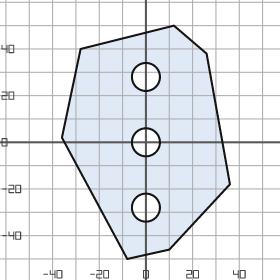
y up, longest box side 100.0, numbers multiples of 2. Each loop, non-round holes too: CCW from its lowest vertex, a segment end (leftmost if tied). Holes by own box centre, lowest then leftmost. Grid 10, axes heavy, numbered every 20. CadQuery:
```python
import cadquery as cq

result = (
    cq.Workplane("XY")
    .moveTo(-8.0, -50.0)
    .lineTo(10.0, -46.0)
    .lineTo(36.0, -18.0)
    .lineTo(26.0, 38.0)
    .lineTo(12.0, 50.0)
    .lineTo(-28.0, 40.0)
    .lineTo(-36.0, 2.0)
    .close()
    .moveTo(0.0, -28.0)
    .circle(6.0)
    .moveTo(0.0, 0.0)
    .circle(6.0)
    .moveTo(0.0, 28.0)
    .circle(6.0)
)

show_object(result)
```